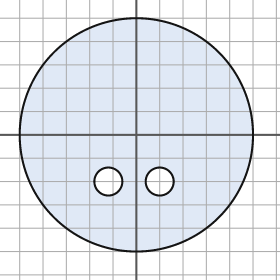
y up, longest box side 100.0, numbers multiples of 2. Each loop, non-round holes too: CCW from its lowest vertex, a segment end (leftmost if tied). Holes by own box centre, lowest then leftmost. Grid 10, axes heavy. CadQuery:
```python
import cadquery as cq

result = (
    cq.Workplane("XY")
    .moveTo(0.0, 0.0)
    .circle(50.0)
    .moveTo(-12.0, -20.0)
    .circle(6.0)
    .moveTo(10.0, -20.0)
    .circle(6.0)
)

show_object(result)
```